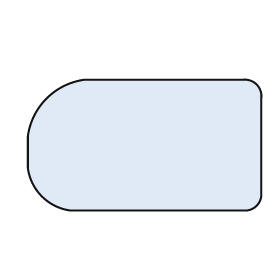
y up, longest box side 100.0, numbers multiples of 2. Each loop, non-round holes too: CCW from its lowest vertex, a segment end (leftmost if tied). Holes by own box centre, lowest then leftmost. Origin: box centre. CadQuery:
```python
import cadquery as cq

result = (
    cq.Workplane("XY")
    .moveTo(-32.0, -28.0)
    .lineTo(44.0, -28.0)
    .threePointArc((48.0, -26.0), (50.0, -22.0))
    .lineTo(50.0, 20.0)
    .threePointArc((48.0, 26.0), (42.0, 28.0))
    .lineTo(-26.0, 28.0)
    .threePointArc((-42.0, 20.0), (-50.0, 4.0))
    .lineTo(-50.0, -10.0)
    .threePointArc((-44.0, -22.0), (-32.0, -28.0))
    .close()
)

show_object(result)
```